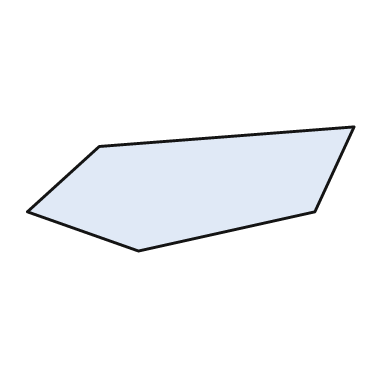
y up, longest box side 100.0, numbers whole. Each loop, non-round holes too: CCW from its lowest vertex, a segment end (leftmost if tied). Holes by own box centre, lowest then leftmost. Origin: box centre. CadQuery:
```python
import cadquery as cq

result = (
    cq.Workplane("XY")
    .moveTo(-16.0, -19.0)
    .lineTo(38.0, -7.0)
    .lineTo(50.0, 19.0)
    .lineTo(-28.0, 13.0)
    .lineTo(-50.0, -7.0)
    .close()
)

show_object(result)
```